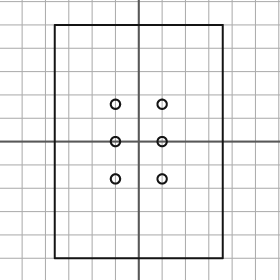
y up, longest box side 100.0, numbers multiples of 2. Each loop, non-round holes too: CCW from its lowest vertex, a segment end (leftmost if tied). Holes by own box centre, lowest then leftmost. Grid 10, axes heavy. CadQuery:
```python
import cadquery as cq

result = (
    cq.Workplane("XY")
    .moveTo(-36.0, -50.0)
    .lineTo(36.0, -50.0)
    .lineTo(36.0, 50.0)
    .lineTo(-36.0, 50.0)
    .close()
    .moveTo(-10.0, -16.0)
    .circle(2.0)
    .moveTo(10.0, -16.0)
    .circle(2.0)
    .moveTo(-10.0, 0.0)
    .circle(2.0)
    .moveTo(10.0, 0.0)
    .circle(2.0)
    .moveTo(-10.0, 16.0)
    .circle(2.0)
    .moveTo(10.0, 16.0)
    .circle(2.0)
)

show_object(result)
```